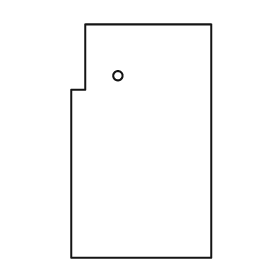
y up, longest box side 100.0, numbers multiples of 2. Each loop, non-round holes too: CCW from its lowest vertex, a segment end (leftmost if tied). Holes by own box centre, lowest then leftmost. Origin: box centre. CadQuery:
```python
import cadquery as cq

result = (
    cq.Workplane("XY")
    .moveTo(-30.0, -50.0)
    .lineTo(30.0, -50.0)
    .lineTo(30.0, 50.0)
    .lineTo(-24.0, 50.0)
    .lineTo(-24.0, 22.0)
    .lineTo(-30.0, 22.0)
    .close()
    .moveTo(-10.0, 28.0)
    .circle(2.0)
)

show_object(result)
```